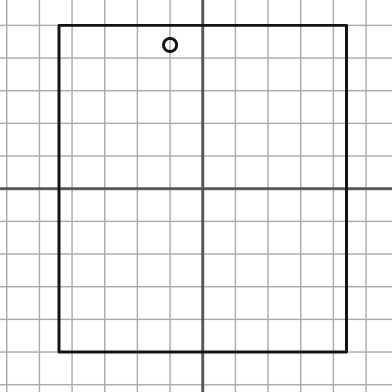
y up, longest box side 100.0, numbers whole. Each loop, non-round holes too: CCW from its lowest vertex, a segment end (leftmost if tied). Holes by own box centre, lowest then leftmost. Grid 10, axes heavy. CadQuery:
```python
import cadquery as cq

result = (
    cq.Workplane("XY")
    .moveTo(-44.0, -50.0)
    .lineTo(44.0, -50.0)
    .lineTo(44.0, 50.0)
    .lineTo(-44.0, 50.0)
    .close()
    .moveTo(-10.0, 44.0)
    .circle(2.0)
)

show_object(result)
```